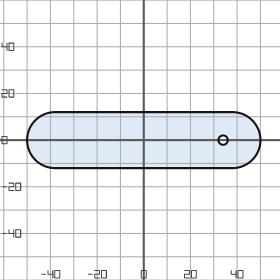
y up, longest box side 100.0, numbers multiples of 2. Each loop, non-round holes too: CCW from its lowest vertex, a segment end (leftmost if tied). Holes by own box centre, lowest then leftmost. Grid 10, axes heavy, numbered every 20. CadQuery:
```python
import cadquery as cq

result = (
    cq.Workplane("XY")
    .moveTo(-38.0, -12.0)
    .lineTo(38.0, -12.0)
    .threePointArc((50.0, 0.0), (38.0, 12.0))
    .lineTo(-38.0, 12.0)
    .threePointArc((-50.0, 0.0), (-38.0, -12.0))
    .close()
    .moveTo(34.0, 0.0)
    .circle(2.0)
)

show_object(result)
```